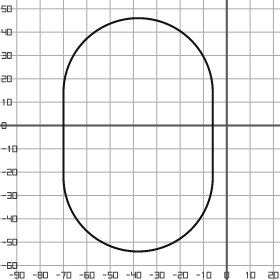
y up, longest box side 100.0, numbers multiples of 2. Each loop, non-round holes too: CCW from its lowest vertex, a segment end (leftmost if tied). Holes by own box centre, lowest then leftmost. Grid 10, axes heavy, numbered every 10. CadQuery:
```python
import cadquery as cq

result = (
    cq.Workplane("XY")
    .moveTo(-70.0, -22.0)
    .threePointArc((-38.0, -54.0), (-6.0, -22.0))
    .lineTo(-6.0, 14.0)
    .threePointArc((-38.0, 46.0), (-70.0, 14.0))
    .close()
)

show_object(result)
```